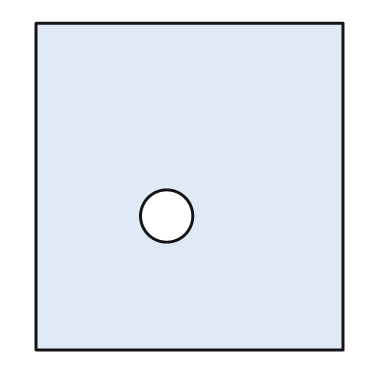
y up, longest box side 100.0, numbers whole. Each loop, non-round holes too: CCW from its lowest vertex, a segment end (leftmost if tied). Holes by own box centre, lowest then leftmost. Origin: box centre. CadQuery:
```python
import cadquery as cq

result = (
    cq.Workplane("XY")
    .moveTo(-47.0, -50.0)
    .lineTo(47.0, -50.0)
    .lineTo(47.0, 50.0)
    .lineTo(-47.0, 50.0)
    .close()
    .moveTo(-7.0, -9.0)
    .circle(8.0)
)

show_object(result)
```